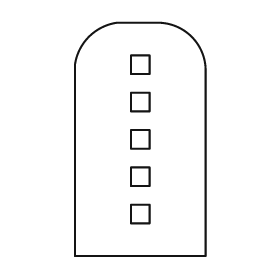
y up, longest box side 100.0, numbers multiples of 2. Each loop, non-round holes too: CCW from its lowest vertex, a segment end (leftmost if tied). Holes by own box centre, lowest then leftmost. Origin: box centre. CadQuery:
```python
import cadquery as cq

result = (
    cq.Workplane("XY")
    .moveTo(-28.0, -50.0)
    .lineTo(28.0, -50.0)
    .lineTo(28.0, 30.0)
    .threePointArc((22.0, 44.0), (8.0, 50.0))
    .lineTo(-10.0, 50.0)
    .threePointArc((-22.0, 44.0), (-28.0, 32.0))
    .close()
    .moveTo(-4.0, -36.0)
    .lineTo(4.0, -36.0)
    .lineTo(4.0, -28.0)
    .lineTo(-4.0, -28.0)
    .close()
    .moveTo(-4.0, -20.0)
    .lineTo(4.0, -20.0)
    .lineTo(4.0, -12.0)
    .lineTo(-4.0, -12.0)
    .close()
    .moveTo(-4.0, -4.0)
    .lineTo(4.0, -4.0)
    .lineTo(4.0, 4.0)
    .lineTo(-4.0, 4.0)
    .close()
    .moveTo(-4.0, 12.0)
    .lineTo(4.0, 12.0)
    .lineTo(4.0, 20.0)
    .lineTo(-4.0, 20.0)
    .close()
    .moveTo(-4.0, 28.0)
    .lineTo(4.0, 28.0)
    .lineTo(4.0, 36.0)
    .lineTo(-4.0, 36.0)
    .close()
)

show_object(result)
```